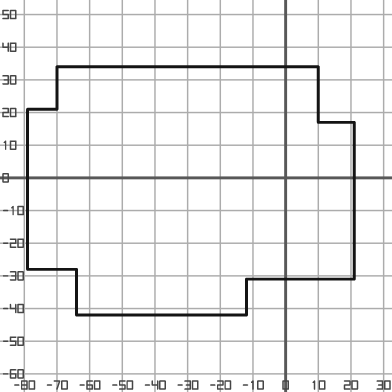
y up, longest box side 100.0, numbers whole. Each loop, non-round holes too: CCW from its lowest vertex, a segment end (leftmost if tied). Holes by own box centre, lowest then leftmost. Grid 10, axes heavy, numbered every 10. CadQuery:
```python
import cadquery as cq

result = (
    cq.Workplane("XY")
    .moveTo(-64.0, -42.0)
    .lineTo(-12.0, -42.0)
    .lineTo(-12.0, -31.0)
    .lineTo(21.0, -31.0)
    .lineTo(21.0, 17.0)
    .lineTo(10.0, 17.0)
    .lineTo(10.0, 34.0)
    .lineTo(-70.0, 34.0)
    .lineTo(-70.0, 21.0)
    .lineTo(-79.0, 21.0)
    .lineTo(-79.0, -28.0)
    .lineTo(-64.0, -28.0)
    .close()
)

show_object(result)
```